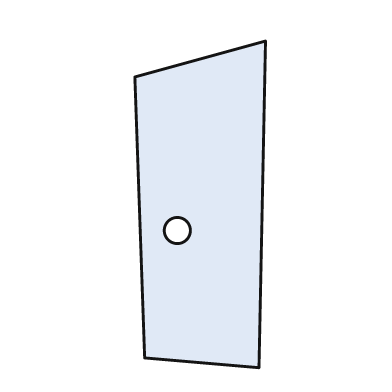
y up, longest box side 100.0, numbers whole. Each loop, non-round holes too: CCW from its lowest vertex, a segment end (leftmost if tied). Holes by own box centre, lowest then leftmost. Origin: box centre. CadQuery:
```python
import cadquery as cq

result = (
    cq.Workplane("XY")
    .moveTo(18.0, -50.0)
    .lineTo(20.0, 50.0)
    .lineTo(-20.0, 39.0)
    .lineTo(-17.0, -47.0)
    .close()
    .moveTo(-7.0, -8.0)
    .circle(4.0)
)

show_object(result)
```